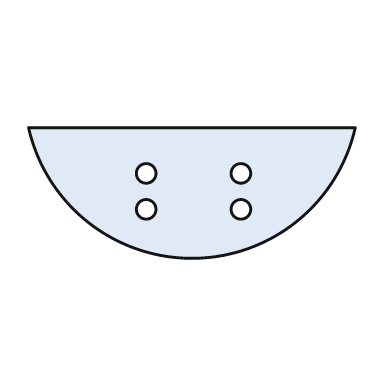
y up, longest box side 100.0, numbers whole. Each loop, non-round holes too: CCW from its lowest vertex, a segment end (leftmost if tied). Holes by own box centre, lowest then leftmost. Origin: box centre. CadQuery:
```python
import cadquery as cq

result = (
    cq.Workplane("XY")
    .moveTo(-50.0, 20.0)
    .threePointArc((0.0, -20.0), (50.0, 20.0))
    .close()
    .moveTo(-14.0, -5.0)
    .circle(3.0)
    .moveTo(15.0, -5.0)
    .circle(3.0)
    .moveTo(-14.0, 6.0)
    .circle(3.0)
    .moveTo(15.0, 6.0)
    .circle(3.0)
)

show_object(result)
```